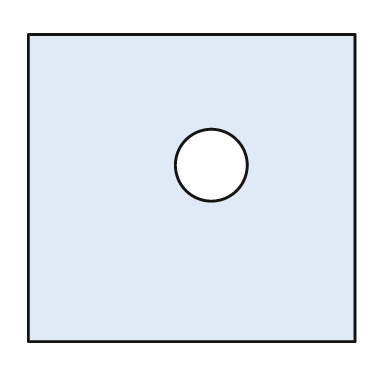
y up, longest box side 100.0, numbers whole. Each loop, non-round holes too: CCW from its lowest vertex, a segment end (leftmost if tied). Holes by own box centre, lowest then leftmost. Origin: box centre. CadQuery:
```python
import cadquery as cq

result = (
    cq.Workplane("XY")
    .moveTo(-50.0, -47.0)
    .lineTo(50.0, -47.0)
    .lineTo(50.0, 47.0)
    .lineTo(-50.0, 47.0)
    .close()
    .moveTo(6.0, 7.0)
    .circle(11.0)
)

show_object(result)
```